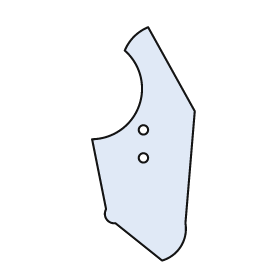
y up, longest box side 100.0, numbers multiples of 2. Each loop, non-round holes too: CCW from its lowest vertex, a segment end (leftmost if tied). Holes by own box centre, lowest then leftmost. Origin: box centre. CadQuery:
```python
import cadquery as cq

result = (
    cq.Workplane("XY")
    .moveTo(8.0, -50.0)
    .threePointArc((16.0, -44.0), (18.0, -34.0))
    .lineTo(22.0, 14.0)
    .lineTo(2.0, 50.0)
    .threePointArc((-4.0, 46.0), (-8.0, 40.0))
    .threePointArc((-2.0, 16.0), (-22.0, 2.0))
    .lineTo(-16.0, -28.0)
    .threePointArc((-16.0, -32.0), (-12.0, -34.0))
    .close()
    .moveTo(0.0, -6.0)
    .circle(2.0)
    .moveTo(0.0, 6.0)
    .circle(2.0)
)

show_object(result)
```